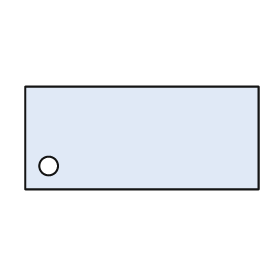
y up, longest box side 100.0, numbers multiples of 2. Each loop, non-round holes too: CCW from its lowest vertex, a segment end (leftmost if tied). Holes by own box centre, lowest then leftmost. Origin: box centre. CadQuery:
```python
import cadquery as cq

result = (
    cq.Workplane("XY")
    .moveTo(-50.0, -22.0)
    .lineTo(50.0, -22.0)
    .lineTo(50.0, 22.0)
    .lineTo(-50.0, 22.0)
    .close()
    .moveTo(-40.0, -12.0)
    .circle(4.0)
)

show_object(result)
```